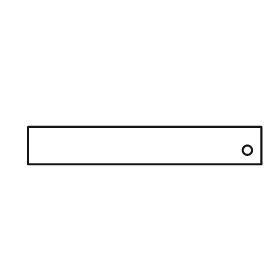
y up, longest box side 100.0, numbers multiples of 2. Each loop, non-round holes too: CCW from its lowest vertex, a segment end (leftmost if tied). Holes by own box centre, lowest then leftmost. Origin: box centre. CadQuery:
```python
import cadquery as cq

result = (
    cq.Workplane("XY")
    .moveTo(-50.0, -8.0)
    .lineTo(50.0, -8.0)
    .lineTo(50.0, 8.0)
    .lineTo(-50.0, 8.0)
    .close()
    .moveTo(44.0, -2.0)
    .circle(2.0)
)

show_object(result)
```